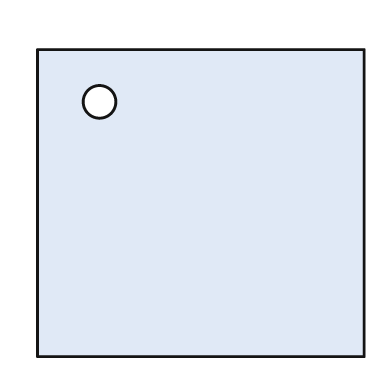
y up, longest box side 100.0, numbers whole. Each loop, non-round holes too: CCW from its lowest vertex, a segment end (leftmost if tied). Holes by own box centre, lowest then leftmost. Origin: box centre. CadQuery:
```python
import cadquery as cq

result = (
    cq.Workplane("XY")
    .moveTo(-50.0, -47.0)
    .lineTo(50.0, -47.0)
    .lineTo(50.0, 47.0)
    .lineTo(-50.0, 47.0)
    .close()
    .moveTo(-31.0, 31.0)
    .circle(5.0)
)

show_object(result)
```